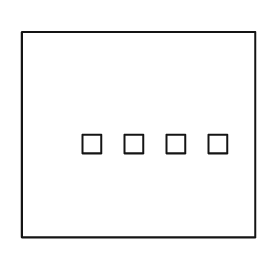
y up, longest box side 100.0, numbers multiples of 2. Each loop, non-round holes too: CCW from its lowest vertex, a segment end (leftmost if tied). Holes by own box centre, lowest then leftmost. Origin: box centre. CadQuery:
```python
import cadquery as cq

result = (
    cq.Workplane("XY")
    .moveTo(-50.0, -44.0)
    .lineTo(50.0, -44.0)
    .lineTo(50.0, 44.0)
    .lineTo(-50.0, 44.0)
    .close()
    .moveTo(-24.0, -8.0)
    .lineTo(-16.0, -8.0)
    .lineTo(-16.0, 0.0)
    .lineTo(-24.0, 0.0)
    .close()
    .moveTo(-6.0, -8.0)
    .lineTo(2.0, -8.0)
    .lineTo(2.0, 0.0)
    .lineTo(-6.0, 0.0)
    .close()
    .moveTo(12.0, -8.0)
    .lineTo(20.0, -8.0)
    .lineTo(20.0, 0.0)
    .lineTo(12.0, 0.0)
    .close()
    .moveTo(30.0, -8.0)
    .lineTo(38.0, -8.0)
    .lineTo(38.0, 0.0)
    .lineTo(30.0, 0.0)
    .close()
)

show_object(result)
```